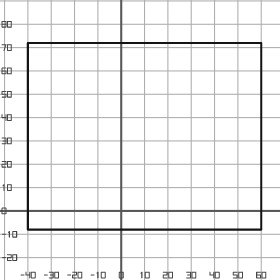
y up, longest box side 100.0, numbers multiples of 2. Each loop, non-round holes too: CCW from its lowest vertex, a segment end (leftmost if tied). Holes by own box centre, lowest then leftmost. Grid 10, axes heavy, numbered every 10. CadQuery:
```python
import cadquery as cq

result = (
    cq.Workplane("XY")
    .moveTo(-40.0, -8.0)
    .lineTo(60.0, -8.0)
    .lineTo(60.0, 72.0)
    .lineTo(-40.0, 72.0)
    .close()
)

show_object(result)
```